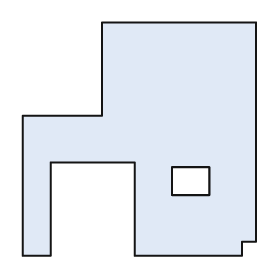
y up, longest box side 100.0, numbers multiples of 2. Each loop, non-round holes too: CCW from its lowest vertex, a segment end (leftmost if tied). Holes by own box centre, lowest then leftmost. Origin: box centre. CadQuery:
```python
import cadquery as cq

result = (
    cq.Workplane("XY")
    .moveTo(-50.0, -50.0)
    .lineTo(-38.0, -50.0)
    .lineTo(-38.0, -10.0)
    .lineTo(-2.0, -10.0)
    .lineTo(-2.0, -50.0)
    .lineTo(44.0, -50.0)
    .lineTo(44.0, -44.0)
    .lineTo(50.0, -44.0)
    .lineTo(50.0, 50.0)
    .lineTo(-16.0, 50.0)
    .lineTo(-16.0, 10.0)
    .lineTo(-50.0, 10.0)
    .close()
    .moveTo(14.0, -24.0)
    .lineTo(30.0, -24.0)
    .lineTo(30.0, -12.0)
    .lineTo(14.0, -12.0)
    .close()
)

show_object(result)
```